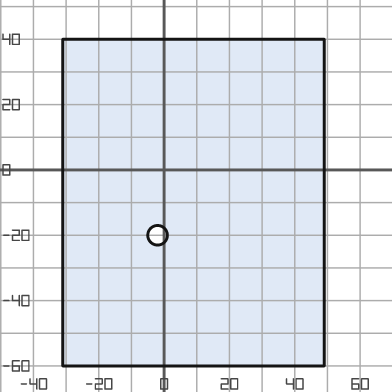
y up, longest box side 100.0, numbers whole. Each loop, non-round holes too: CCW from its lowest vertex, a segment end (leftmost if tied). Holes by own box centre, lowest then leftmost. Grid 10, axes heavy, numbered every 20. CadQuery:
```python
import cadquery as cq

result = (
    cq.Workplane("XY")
    .moveTo(-31.0, -60.0)
    .lineTo(49.0, -60.0)
    .lineTo(49.0, 40.0)
    .lineTo(-31.0, 40.0)
    .close()
    .moveTo(-2.0, -20.0)
    .circle(3.0)
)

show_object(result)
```